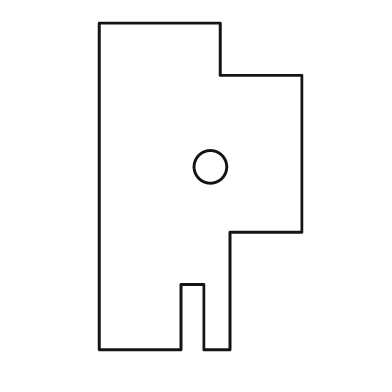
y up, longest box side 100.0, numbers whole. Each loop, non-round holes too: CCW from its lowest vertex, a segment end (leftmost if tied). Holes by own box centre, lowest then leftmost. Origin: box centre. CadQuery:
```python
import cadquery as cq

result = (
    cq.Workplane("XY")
    .moveTo(-31.0, -50.0)
    .lineTo(-6.0, -50.0)
    .lineTo(-6.0, -30.0)
    .lineTo(1.0, -30.0)
    .lineTo(1.0, -50.0)
    .lineTo(9.0, -50.0)
    .lineTo(9.0, -14.0)
    .lineTo(31.0, -14.0)
    .lineTo(31.0, 34.0)
    .lineTo(6.0, 34.0)
    .lineTo(6.0, 50.0)
    .lineTo(-31.0, 50.0)
    .close()
    .moveTo(3.0, 6.0)
    .circle(5.0)
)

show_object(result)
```